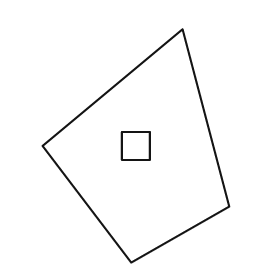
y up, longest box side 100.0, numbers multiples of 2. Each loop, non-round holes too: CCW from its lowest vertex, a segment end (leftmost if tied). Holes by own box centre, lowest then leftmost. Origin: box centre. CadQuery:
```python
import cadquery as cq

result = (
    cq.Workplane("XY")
    .moveTo(-2.0, -50.0)
    .lineTo(40.0, -26.0)
    .lineTo(20.0, 50.0)
    .lineTo(-40.0, 0.0)
    .close()
    .moveTo(-6.0, -6.0)
    .lineTo(6.0, -6.0)
    .lineTo(6.0, 6.0)
    .lineTo(-6.0, 6.0)
    .close()
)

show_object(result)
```